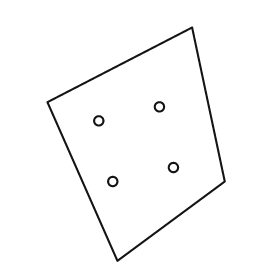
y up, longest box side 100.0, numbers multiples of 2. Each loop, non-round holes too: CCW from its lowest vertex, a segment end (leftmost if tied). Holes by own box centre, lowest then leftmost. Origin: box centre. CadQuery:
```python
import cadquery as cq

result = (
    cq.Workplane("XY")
    .moveTo(-8.0, -50.0)
    .lineTo(38.0, -16.0)
    .lineTo(24.0, 50.0)
    .lineTo(-38.0, 18.0)
    .close()
    .moveTo(-10.0, -16.0)
    .circle(2.0)
    .moveTo(16.0, -10.0)
    .circle(2.0)
    .moveTo(-16.0, 10.0)
    .circle(2.0)
    .moveTo(10.0, 16.0)
    .circle(2.0)
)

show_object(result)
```